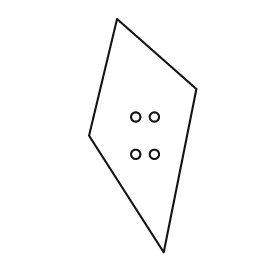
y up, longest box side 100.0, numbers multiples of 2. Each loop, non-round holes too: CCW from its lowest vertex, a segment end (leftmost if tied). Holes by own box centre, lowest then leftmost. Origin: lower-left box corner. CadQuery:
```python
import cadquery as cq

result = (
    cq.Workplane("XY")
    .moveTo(32.0, 0.0)
    .lineTo(46.0, 70.0)
    .lineTo(12.0, 100.0)
    .lineTo(0.0, 50.0)
    .close()
    .moveTo(20.0, 42.0)
    .circle(2.0)
    .moveTo(28.0, 42.0)
    .circle(2.0)
    .moveTo(20.0, 58.0)
    .circle(2.0)
    .moveTo(28.0, 58.0)
    .circle(2.0)
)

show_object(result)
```